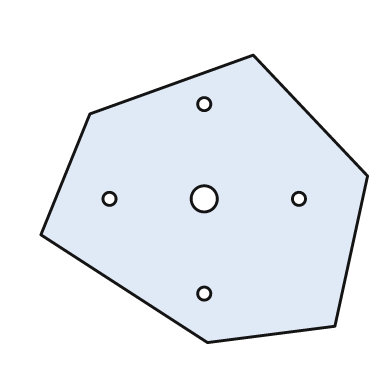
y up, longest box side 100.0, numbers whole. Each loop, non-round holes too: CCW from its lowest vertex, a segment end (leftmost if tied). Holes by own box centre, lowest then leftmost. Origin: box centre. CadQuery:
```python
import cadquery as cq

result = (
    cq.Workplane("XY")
    .moveTo(1.0, -44.0)
    .lineTo(40.0, -39.0)
    .lineTo(50.0, 7.0)
    .lineTo(15.0, 44.0)
    .lineTo(-35.0, 26.0)
    .lineTo(-50.0, -11.0)
    .close()
    .moveTo(0.0, -29.0)
    .circle(2.0)
    .moveTo(-29.0, 0.0)
    .circle(2.0)
    .moveTo(0.0, 0.0)
    .circle(4.0)
    .moveTo(29.0, 0.0)
    .circle(2.0)
    .moveTo(0.0, 29.0)
    .circle(2.0)
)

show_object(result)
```